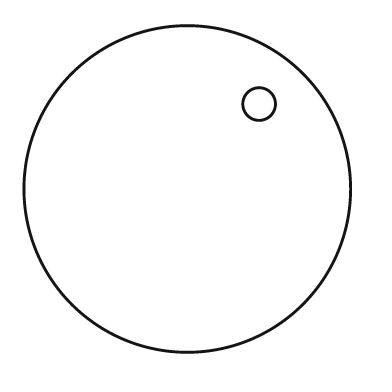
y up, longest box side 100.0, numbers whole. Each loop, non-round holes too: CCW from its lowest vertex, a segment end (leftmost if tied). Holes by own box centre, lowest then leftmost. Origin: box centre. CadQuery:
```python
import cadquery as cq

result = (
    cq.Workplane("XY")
    .moveTo(0.0, 0.0)
    .circle(50.0)
    .moveTo(22.0, 26.0)
    .circle(5.0)
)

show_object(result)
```